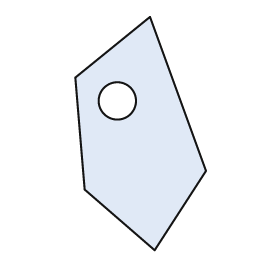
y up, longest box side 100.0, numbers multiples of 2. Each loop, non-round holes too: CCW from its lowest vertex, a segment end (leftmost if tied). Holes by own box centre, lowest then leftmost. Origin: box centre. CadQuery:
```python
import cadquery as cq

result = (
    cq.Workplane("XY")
    .moveTo(6.0, -50.0)
    .lineTo(28.0, -16.0)
    .lineTo(4.0, 50.0)
    .lineTo(-28.0, 24.0)
    .lineTo(-24.0, -24.0)
    .close()
    .moveTo(-10.0, 14.0)
    .circle(8.0)
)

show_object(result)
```